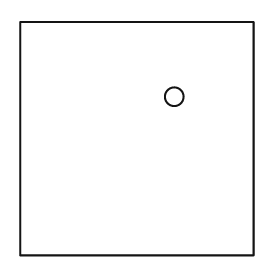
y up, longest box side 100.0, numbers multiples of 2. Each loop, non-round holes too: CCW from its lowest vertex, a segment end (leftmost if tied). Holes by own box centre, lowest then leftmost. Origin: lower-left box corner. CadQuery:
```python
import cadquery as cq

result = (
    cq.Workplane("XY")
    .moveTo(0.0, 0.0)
    .lineTo(100.0, 0.0)
    .lineTo(100.0, 100.0)
    .lineTo(0.0, 100.0)
    .close()
    .moveTo(66.0, 68.0)
    .circle(4.0)
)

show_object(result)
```